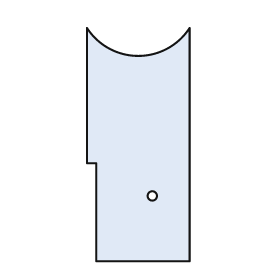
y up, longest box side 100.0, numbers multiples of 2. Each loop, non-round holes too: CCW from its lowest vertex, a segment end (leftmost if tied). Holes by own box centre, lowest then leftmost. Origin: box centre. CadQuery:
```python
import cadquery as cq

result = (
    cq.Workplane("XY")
    .moveTo(-18.0, -50.0)
    .lineTo(22.0, -50.0)
    .lineTo(22.0, 50.0)
    .threePointArc((0.0, 38.0), (-22.0, 50.0))
    .lineTo(-22.0, -8.0)
    .lineTo(-18.0, -8.0)
    .close()
    .moveTo(6.0, -22.0)
    .circle(2.0)
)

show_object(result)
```